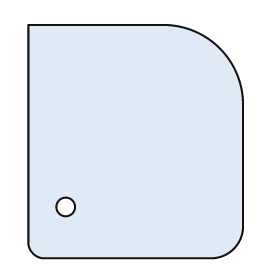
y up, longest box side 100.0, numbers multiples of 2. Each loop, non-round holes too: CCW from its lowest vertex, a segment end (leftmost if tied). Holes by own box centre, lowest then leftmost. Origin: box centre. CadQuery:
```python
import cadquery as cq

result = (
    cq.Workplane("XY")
    .moveTo(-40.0, -50.0)
    .lineTo(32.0, -50.0)
    .threePointArc((42.0, -46.0), (46.0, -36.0))
    .lineTo(46.0, 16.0)
    .threePointArc((36.0, 40.0), (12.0, 50.0))
    .lineTo(-46.0, 50.0)
    .lineTo(-46.0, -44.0)
    .threePointArc((-44.0, -48.0), (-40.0, -50.0))
    .close()
    .moveTo(-30.0, -28.0)
    .circle(4.0)
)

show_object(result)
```